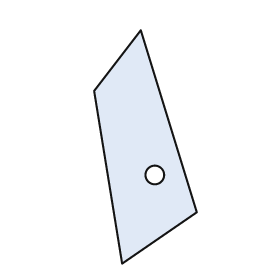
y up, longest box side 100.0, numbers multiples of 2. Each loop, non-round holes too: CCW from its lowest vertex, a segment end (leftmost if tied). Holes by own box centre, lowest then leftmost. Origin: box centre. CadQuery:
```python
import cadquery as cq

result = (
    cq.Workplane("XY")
    .moveTo(-10.0, -50.0)
    .lineTo(22.0, -28.0)
    .lineTo(-2.0, 50.0)
    .lineTo(-22.0, 24.0)
    .close()
    .moveTo(4.0, -12.0)
    .circle(4.0)
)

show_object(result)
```